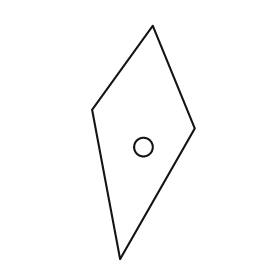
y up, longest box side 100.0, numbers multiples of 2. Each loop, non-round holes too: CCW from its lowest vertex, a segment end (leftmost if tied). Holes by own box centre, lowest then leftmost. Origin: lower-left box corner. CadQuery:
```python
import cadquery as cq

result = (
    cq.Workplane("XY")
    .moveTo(12.0, 0.0)
    .lineTo(44.0, 56.0)
    .lineTo(26.0, 100.0)
    .lineTo(0.0, 64.0)
    .close()
    .moveTo(22.0, 48.0)
    .circle(4.0)
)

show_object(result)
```